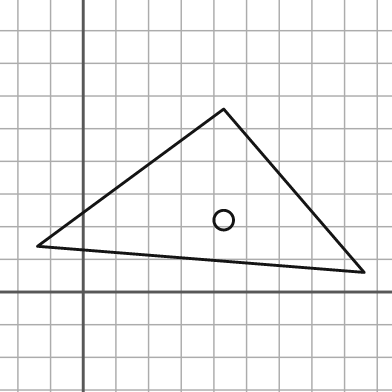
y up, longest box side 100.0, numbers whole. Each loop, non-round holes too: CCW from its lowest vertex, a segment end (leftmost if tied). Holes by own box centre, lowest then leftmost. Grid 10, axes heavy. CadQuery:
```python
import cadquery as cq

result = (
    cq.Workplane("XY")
    .moveTo(86.0, 6.0)
    .lineTo(43.0, 56.0)
    .lineTo(-14.0, 14.0)
    .close()
    .moveTo(43.0, 22.0)
    .circle(3.0)
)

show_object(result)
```